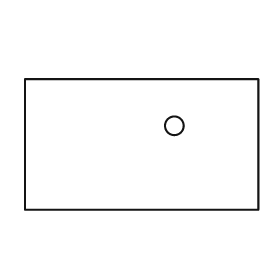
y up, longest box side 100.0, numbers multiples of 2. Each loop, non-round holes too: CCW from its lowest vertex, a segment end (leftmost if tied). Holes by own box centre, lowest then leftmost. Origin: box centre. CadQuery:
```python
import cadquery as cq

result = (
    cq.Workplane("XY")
    .moveTo(-50.0, -28.0)
    .lineTo(50.0, -28.0)
    .lineTo(50.0, 28.0)
    .lineTo(-50.0, 28.0)
    .close()
    .moveTo(14.0, 8.0)
    .circle(4.0)
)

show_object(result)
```